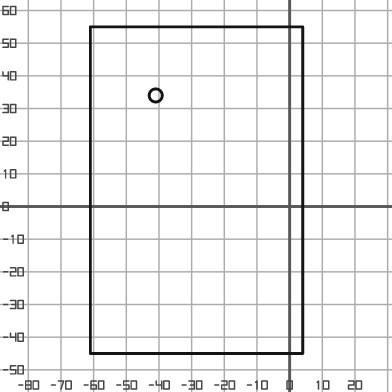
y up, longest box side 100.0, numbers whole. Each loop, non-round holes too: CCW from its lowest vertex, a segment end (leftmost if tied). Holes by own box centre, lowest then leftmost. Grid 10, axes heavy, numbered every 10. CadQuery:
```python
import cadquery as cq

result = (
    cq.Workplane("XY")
    .moveTo(-61.0, -45.0)
    .lineTo(4.0, -45.0)
    .lineTo(4.0, 55.0)
    .lineTo(-61.0, 55.0)
    .close()
    .moveTo(-41.0, 34.0)
    .circle(2.0)
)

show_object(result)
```